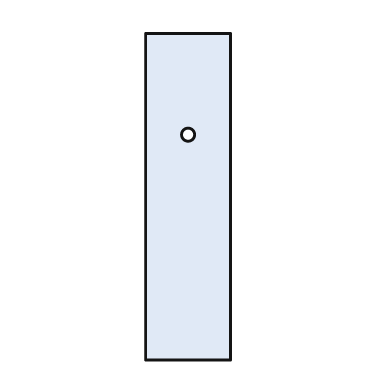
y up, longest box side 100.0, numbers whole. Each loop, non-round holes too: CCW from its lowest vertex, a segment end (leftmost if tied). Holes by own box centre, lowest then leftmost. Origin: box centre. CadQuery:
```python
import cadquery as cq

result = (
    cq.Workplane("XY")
    .moveTo(-13.0, -50.0)
    .lineTo(13.0, -50.0)
    .lineTo(13.0, 50.0)
    .lineTo(-13.0, 50.0)
    .close()
    .moveTo(0.0, 19.0)
    .circle(2.0)
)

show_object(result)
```